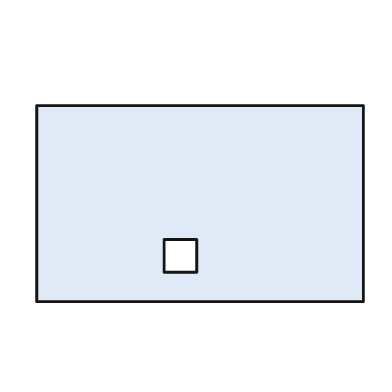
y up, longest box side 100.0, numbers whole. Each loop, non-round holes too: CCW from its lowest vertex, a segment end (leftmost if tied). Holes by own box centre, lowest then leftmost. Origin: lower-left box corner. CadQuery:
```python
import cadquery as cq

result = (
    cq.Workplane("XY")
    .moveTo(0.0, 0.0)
    .lineTo(100.0, 0.0)
    .lineTo(100.0, 60.0)
    .lineTo(0.0, 60.0)
    .close()
    .moveTo(39.0, 9.0)
    .lineTo(49.0, 9.0)
    .lineTo(49.0, 19.0)
    .lineTo(39.0, 19.0)
    .close()
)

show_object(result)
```